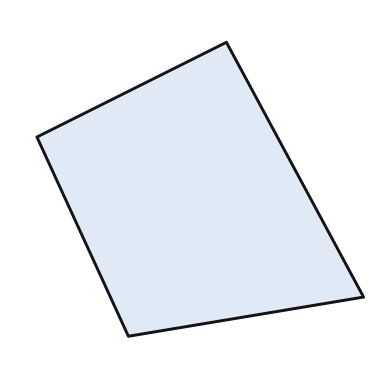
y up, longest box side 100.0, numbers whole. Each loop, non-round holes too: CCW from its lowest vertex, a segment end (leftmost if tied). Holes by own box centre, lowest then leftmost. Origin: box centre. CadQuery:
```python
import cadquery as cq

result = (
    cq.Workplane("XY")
    .moveTo(-22.0, -45.0)
    .lineTo(50.0, -33.0)
    .lineTo(8.0, 45.0)
    .lineTo(-50.0, 16.0)
    .close()
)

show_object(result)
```